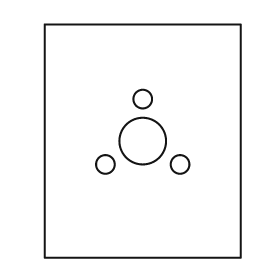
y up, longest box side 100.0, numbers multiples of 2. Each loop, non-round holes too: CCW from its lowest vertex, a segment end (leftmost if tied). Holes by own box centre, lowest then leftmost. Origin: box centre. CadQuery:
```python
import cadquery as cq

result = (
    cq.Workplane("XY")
    .moveTo(-42.0, -50.0)
    .lineTo(42.0, -50.0)
    .lineTo(42.0, 50.0)
    .lineTo(-42.0, 50.0)
    .close()
    .moveTo(-16.0, -10.0)
    .circle(4.0)
    .moveTo(16.0, -10.0)
    .circle(4.0)
    .moveTo(0.0, 0.0)
    .circle(10.0)
    .moveTo(0.0, 18.0)
    .circle(4.0)
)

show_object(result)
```